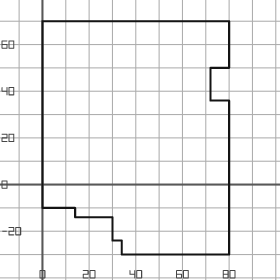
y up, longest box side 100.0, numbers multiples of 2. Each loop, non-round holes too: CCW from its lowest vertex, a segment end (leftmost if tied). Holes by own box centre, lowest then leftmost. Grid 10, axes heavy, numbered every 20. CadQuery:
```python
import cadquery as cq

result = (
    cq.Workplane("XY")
    .moveTo(34.0, -30.0)
    .lineTo(80.0, -30.0)
    .lineTo(80.0, 36.0)
    .lineTo(72.0, 36.0)
    .lineTo(72.0, 50.0)
    .lineTo(80.0, 50.0)
    .lineTo(80.0, 70.0)
    .lineTo(0.0, 70.0)
    .lineTo(0.0, -10.0)
    .lineTo(14.0, -10.0)
    .lineTo(14.0, -14.0)
    .lineTo(30.0, -14.0)
    .lineTo(30.0, -24.0)
    .lineTo(34.0, -24.0)
    .close()
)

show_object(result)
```